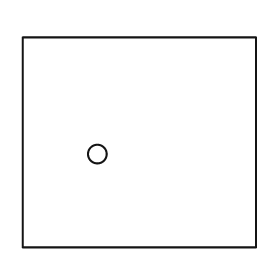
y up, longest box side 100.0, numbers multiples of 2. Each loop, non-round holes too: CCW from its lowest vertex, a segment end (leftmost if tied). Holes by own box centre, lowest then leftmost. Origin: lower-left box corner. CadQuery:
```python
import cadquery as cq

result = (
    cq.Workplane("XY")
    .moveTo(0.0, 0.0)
    .lineTo(100.0, 0.0)
    .lineTo(100.0, 90.0)
    .lineTo(0.0, 90.0)
    .close()
    .moveTo(32.0, 40.0)
    .circle(4.0)
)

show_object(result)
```